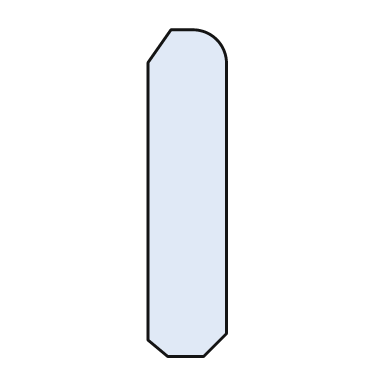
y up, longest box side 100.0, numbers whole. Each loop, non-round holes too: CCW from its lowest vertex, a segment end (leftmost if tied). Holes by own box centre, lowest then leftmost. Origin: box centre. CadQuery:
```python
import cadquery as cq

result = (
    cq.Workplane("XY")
    .moveTo(-6.0, -50.0)
    .lineTo(5.0, -50.0)
    .lineTo(12.0, -43.0)
    .lineTo(12.0, 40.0)
    .threePointArc((9.0, 47.0), (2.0, 50.0))
    .lineTo(-5.0, 50.0)
    .lineTo(-12.0, 40.0)
    .lineTo(-12.0, -45.0)
    .close()
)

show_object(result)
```